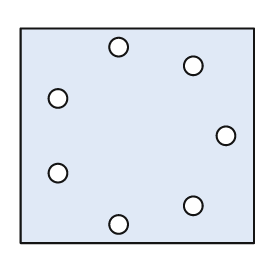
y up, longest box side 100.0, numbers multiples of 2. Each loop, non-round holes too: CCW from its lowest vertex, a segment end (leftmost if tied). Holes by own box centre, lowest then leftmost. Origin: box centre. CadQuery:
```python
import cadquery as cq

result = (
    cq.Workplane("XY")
    .moveTo(-50.0, -46.0)
    .lineTo(50.0, -46.0)
    .lineTo(50.0, 46.0)
    .lineTo(-50.0, 46.0)
    .close()
    .moveTo(-8.0, -38.0)
    .circle(4.0)
    .moveTo(24.0, -30.0)
    .circle(4.0)
    .moveTo(-34.0, -16.0)
    .circle(4.0)
    .moveTo(38.0, 0.0)
    .circle(4.0)
    .moveTo(-34.0, 16.0)
    .circle(4.0)
    .moveTo(24.0, 30.0)
    .circle(4.0)
    .moveTo(-8.0, 38.0)
    .circle(4.0)
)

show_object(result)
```